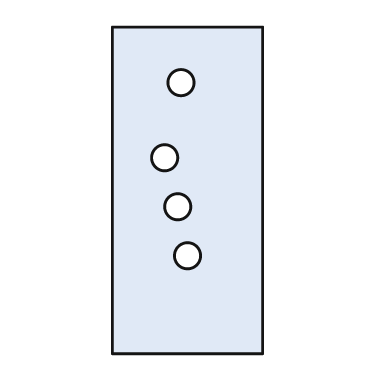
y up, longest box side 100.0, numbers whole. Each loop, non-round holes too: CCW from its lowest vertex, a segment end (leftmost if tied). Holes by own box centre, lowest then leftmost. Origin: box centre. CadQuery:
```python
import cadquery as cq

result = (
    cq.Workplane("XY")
    .moveTo(-23.0, -50.0)
    .lineTo(23.0, -50.0)
    .lineTo(23.0, 50.0)
    .lineTo(-23.0, 50.0)
    .close()
    .moveTo(0.0, -20.0)
    .circle(4.0)
    .moveTo(-3.0, -5.0)
    .circle(4.0)
    .moveTo(-7.0, 10.0)
    .circle(4.0)
    .moveTo(-2.0, 33.0)
    .circle(4.0)
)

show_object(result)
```